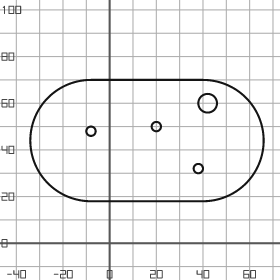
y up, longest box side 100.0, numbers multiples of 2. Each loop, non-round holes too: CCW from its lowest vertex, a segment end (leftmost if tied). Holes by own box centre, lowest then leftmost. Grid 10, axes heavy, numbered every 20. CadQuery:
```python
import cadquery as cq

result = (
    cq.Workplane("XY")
    .moveTo(-8.0, 18.0)
    .lineTo(40.0, 18.0)
    .threePointArc((66.0, 44.0), (40.0, 70.0))
    .lineTo(-8.0, 70.0)
    .threePointArc((-34.0, 44.0), (-8.0, 18.0))
    .close()
    .moveTo(38.0, 32.0)
    .circle(2.0)
    .moveTo(-8.0, 48.0)
    .circle(2.0)
    .moveTo(20.0, 50.0)
    .circle(2.0)
    .moveTo(42.0, 60.0)
    .circle(4.0)
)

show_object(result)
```